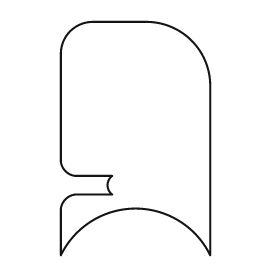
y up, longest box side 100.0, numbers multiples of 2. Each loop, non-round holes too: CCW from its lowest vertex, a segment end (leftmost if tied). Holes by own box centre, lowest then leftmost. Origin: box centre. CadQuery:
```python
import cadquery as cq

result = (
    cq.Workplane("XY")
    .moveTo(-32.0, -50.0)
    .threePointArc((0.0, -30.0), (32.0, -50.0))
    .lineTo(32.0, 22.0)
    .threePointArc((24.0, 42.0), (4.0, 50.0))
    .lineTo(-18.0, 50.0)
    .threePointArc((-28.0, 46.0), (-32.0, 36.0))
    .lineTo(-32.0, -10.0)
    .threePointArc((-30.0, -14.0), (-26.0, -16.0))
    .lineTo(-10.0, -16.0)
    .threePointArc((-12.0, -20.0), (-10.0, -24.0))
    .lineTo(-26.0, -24.0)
    .threePointArc((-30.0, -26.0), (-32.0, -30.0))
    .close()
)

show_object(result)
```